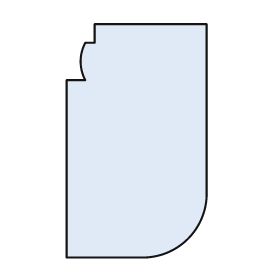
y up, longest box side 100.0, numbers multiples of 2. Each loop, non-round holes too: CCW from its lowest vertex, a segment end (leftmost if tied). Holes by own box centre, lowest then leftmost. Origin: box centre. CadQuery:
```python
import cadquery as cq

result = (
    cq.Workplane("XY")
    .moveTo(-30.0, -50.0)
    .lineTo(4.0, -50.0)
    .threePointArc((22.0, -42.0), (30.0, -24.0))
    .lineTo(30.0, 50.0)
    .lineTo(-18.0, 50.0)
    .lineTo(-18.0, 42.0)
    .lineTo(-22.0, 42.0)
    .threePointArc((-24.0, 34.0), (-22.0, 26.0))
    .lineTo(-30.0, 26.0)
    .close()
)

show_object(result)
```